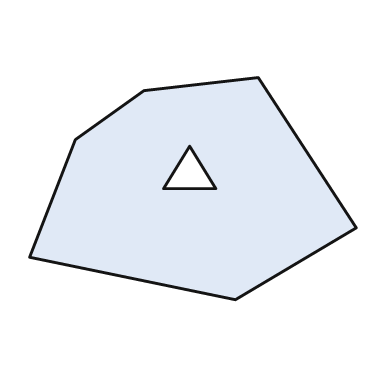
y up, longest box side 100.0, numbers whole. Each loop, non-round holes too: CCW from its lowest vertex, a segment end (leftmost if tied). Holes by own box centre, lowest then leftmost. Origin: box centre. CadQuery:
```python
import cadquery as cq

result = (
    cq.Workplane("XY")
    .moveTo(13.0, -34.0)
    .lineTo(50.0, -12.0)
    .lineTo(20.0, 34.0)
    .lineTo(-15.0, 30.0)
    .lineTo(-36.0, 15.0)
    .lineTo(-50.0, -21.0)
    .close()
    .moveTo(-9.0, 0.0)
    .lineTo(7.0, 0.0)
    .lineTo(-1.0, 13.0)
    .close()
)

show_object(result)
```